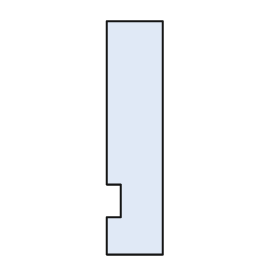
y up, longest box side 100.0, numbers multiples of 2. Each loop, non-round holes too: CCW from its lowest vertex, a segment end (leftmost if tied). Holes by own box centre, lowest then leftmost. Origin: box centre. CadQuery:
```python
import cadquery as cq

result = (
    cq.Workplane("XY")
    .moveTo(-12.0, -50.0)
    .lineTo(12.0, -50.0)
    .lineTo(12.0, 50.0)
    .lineTo(-12.0, 50.0)
    .lineTo(-12.0, -20.0)
    .lineTo(-6.0, -20.0)
    .lineTo(-6.0, -34.0)
    .lineTo(-12.0, -34.0)
    .close()
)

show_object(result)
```